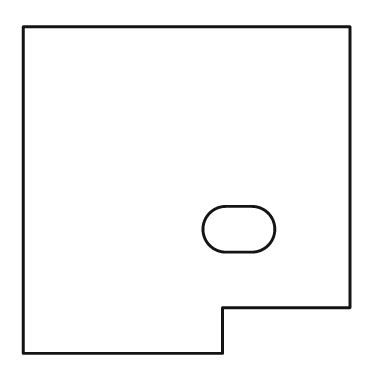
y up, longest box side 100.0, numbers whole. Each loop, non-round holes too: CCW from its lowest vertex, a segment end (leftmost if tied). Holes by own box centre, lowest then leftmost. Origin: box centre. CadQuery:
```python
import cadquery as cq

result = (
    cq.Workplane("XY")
    .moveTo(-50.0, -50.0)
    .lineTo(11.0, -50.0)
    .lineTo(11.0, -36.0)
    .lineTo(50.0, -36.0)
    .lineTo(50.0, 50.0)
    .lineTo(-50.0, 50.0)
    .close()
    .moveTo(12.0, -19.0)
    .lineTo(20.0, -19.0)
    .threePointArc((27.0, -12.0), (20.0, -5.0))
    .lineTo(12.0, -5.0)
    .threePointArc((5.0, -12.0), (12.0, -19.0))
    .close()
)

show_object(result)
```